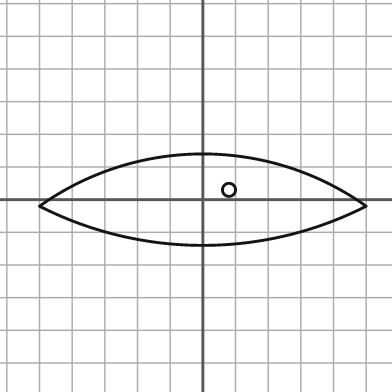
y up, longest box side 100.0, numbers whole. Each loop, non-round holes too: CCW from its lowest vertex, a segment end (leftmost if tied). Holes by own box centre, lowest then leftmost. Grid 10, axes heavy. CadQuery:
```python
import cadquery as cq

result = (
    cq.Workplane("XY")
    .moveTo(-50.0, -2.0)
    .threePointArc((0.0, -14.0), (50.0, -2.0))
    .threePointArc((0.0, 14.0), (-50.0, -2.0))
    .close()
    .moveTo(8.0, 3.0)
    .circle(2.0)
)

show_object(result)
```